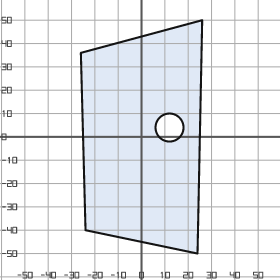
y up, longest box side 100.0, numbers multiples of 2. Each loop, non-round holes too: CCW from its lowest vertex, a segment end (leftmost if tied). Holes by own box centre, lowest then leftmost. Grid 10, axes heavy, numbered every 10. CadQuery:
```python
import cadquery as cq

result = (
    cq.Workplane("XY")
    .moveTo(24.0, -50.0)
    .lineTo(26.0, 50.0)
    .lineTo(-26.0, 36.0)
    .lineTo(-24.0, -40.0)
    .close()
    .moveTo(12.0, 4.0)
    .circle(6.0)
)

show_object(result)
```